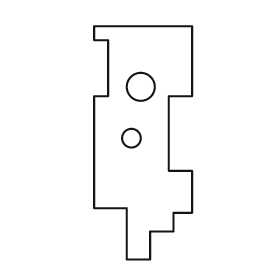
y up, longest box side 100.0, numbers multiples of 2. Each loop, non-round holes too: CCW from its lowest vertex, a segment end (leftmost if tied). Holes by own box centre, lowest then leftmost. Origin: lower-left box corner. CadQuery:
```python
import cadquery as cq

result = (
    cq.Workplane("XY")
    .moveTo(14.0, 0.0)
    .lineTo(24.0, 0.0)
    .lineTo(24.0, 12.0)
    .lineTo(34.0, 12.0)
    .lineTo(34.0, 20.0)
    .lineTo(42.0, 20.0)
    .lineTo(42.0, 38.0)
    .lineTo(32.0, 38.0)
    .lineTo(32.0, 70.0)
    .lineTo(42.0, 70.0)
    .lineTo(42.0, 100.0)
    .lineTo(0.0, 100.0)
    .lineTo(0.0, 94.0)
    .lineTo(6.0, 94.0)
    .lineTo(6.0, 70.0)
    .lineTo(0.0, 70.0)
    .lineTo(0.0, 22.0)
    .lineTo(14.0, 22.0)
    .close()
    .moveTo(16.0, 52.0)
    .circle(4.0)
    .moveTo(20.0, 74.0)
    .circle(6.0)
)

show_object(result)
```